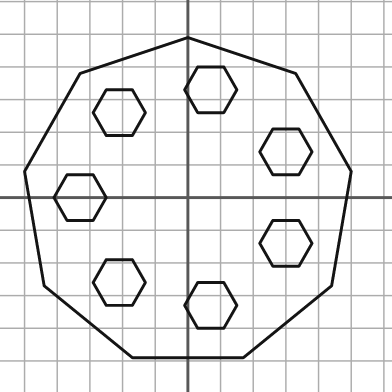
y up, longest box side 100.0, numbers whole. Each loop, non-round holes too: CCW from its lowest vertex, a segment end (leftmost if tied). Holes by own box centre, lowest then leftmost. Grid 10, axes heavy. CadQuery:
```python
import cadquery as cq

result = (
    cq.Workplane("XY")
    .moveTo(-17.0, -49.0)
    .lineTo(17.0, -49.0)
    .lineTo(44.0, -27.0)
    .lineTo(50.0, 8.0)
    .lineTo(33.0, 38.0)
    .lineTo(0.0, 49.0)
    .lineTo(-33.0, 38.0)
    .lineTo(-50.0, 8.0)
    .lineTo(-44.0, -27.0)
    .close()
    .moveTo(3.0, -40.0)
    .lineTo(11.0, -40.0)
    .lineTo(15.0, -33.0)
    .lineTo(11.0, -26.0)
    .lineTo(3.0, -26.0)
    .lineTo(-1.0, -33.0)
    .close()
    .moveTo(-25.0, -33.0)
    .lineTo(-17.0, -33.0)
    .lineTo(-13.0, -26.0)
    .lineTo(-17.0, -19.0)
    .lineTo(-25.0, -19.0)
    .lineTo(-29.0, -26.0)
    .close()
    .moveTo(26.0, -21.0)
    .lineTo(34.0, -21.0)
    .lineTo(38.0, -14.0)
    .lineTo(34.0, -7.0)
    .lineTo(26.0, -7.0)
    .lineTo(22.0, -14.0)
    .close()
    .moveTo(-37.0, -7.0)
    .lineTo(-29.0, -7.0)
    .lineTo(-25.0, 0.0)
    .lineTo(-29.0, 7.0)
    .lineTo(-37.0, 7.0)
    .lineTo(-41.0, 0.0)
    .close()
    .moveTo(26.0, 7.0)
    .lineTo(34.0, 7.0)
    .lineTo(38.0, 14.0)
    .lineTo(34.0, 21.0)
    .lineTo(26.0, 21.0)
    .lineTo(22.0, 14.0)
    .close()
    .moveTo(-25.0, 19.0)
    .lineTo(-17.0, 19.0)
    .lineTo(-13.0, 26.0)
    .lineTo(-17.0, 33.0)
    .lineTo(-25.0, 33.0)
    .lineTo(-29.0, 26.0)
    .close()
    .moveTo(3.0, 26.0)
    .lineTo(11.0, 26.0)
    .lineTo(15.0, 33.0)
    .lineTo(11.0, 40.0)
    .lineTo(3.0, 40.0)
    .lineTo(-1.0, 33.0)
    .close()
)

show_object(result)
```